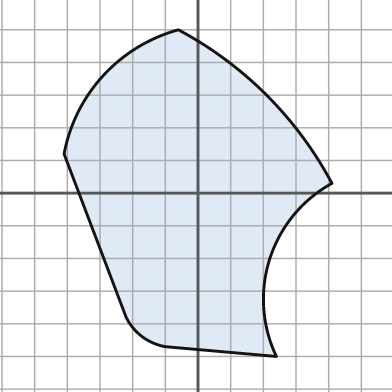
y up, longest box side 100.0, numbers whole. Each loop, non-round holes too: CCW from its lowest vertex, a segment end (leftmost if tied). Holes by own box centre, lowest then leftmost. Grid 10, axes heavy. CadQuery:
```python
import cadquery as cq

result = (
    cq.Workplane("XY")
    .moveTo(24.0, -50.0)
    .threePointArc((22.0, -20.0), (41.0, 3.0))
    .threePointArc((21.0, 30.0), (-6.0, 50.0))
    .threePointArc((-29.0, 36.0), (-41.0, 12.0))
    .lineTo(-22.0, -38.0)
    .threePointArc((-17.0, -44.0), (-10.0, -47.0))
    .close()
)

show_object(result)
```